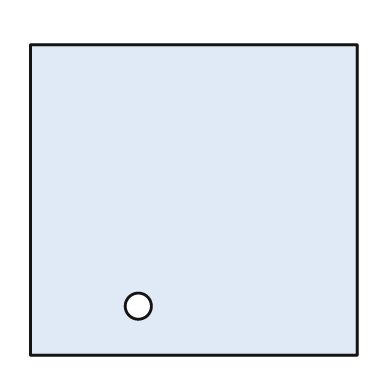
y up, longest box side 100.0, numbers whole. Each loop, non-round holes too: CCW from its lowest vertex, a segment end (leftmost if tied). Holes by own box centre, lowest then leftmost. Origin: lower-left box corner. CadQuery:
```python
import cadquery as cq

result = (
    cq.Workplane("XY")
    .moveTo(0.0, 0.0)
    .lineTo(100.0, 0.0)
    .lineTo(100.0, 95.0)
    .lineTo(0.0, 95.0)
    .close()
    .moveTo(33.0, 15.0)
    .circle(4.0)
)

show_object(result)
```